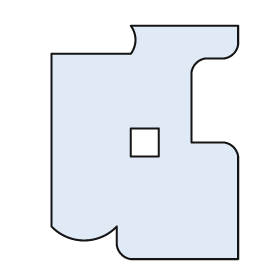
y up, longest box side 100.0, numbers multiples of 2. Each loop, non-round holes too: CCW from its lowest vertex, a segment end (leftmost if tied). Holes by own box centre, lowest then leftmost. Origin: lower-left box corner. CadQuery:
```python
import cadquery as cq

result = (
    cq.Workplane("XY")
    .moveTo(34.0, 0.0)
    .lineTo(80.0, 0.0)
    .lineTo(80.0, 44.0)
    .threePointArc((78.0, 48.0), (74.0, 50.0))
    .lineTo(60.0, 50.0)
    .lineTo(60.0, 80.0)
    .threePointArc((62.0, 84.0), (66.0, 86.0))
    .lineTo(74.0, 86.0)
    .threePointArc((78.0, 88.0), (80.0, 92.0))
    .lineTo(80.0, 100.0)
    .lineTo(34.0, 100.0)
    .threePointArc((36.0, 94.0), (34.0, 88.0))
    .lineTo(0.0, 88.0)
    .lineTo(0.0, 14.0)
    .threePointArc((14.0, 8.0), (28.0, 14.0))
    .lineTo(28.0, 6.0)
    .threePointArc((30.0, 2.0), (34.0, 0.0))
    .close()
    .moveTo(34.0, 44.0)
    .lineTo(46.0, 44.0)
    .lineTo(46.0, 56.0)
    .lineTo(34.0, 56.0)
    .close()
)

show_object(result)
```